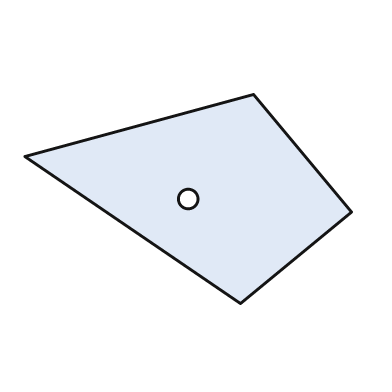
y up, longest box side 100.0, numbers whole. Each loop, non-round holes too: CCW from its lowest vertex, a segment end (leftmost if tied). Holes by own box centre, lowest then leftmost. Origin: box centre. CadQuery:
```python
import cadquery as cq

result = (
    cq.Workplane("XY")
    .moveTo(16.0, -32.0)
    .lineTo(50.0, -4.0)
    .lineTo(20.0, 32.0)
    .lineTo(-50.0, 13.0)
    .close()
    .moveTo(0.0, 0.0)
    .circle(3.0)
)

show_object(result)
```